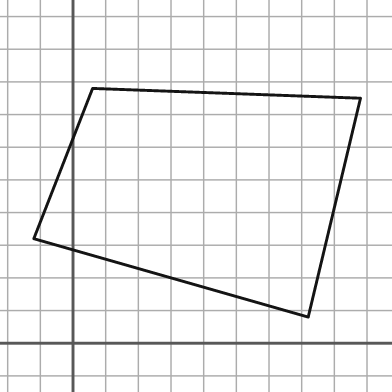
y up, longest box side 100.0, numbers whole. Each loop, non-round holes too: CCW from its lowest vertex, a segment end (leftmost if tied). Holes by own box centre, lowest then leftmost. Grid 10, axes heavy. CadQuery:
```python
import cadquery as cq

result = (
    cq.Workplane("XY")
    .moveTo(72.0, 8.0)
    .lineTo(88.0, 75.0)
    .lineTo(6.0, 78.0)
    .lineTo(-12.0, 32.0)
    .close()
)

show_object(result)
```